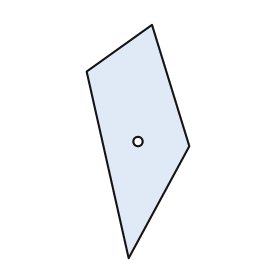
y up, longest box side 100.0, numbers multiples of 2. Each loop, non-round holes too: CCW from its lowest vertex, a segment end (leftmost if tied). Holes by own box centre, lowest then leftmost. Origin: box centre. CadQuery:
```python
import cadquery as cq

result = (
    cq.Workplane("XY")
    .moveTo(-4.0, -50.0)
    .lineTo(22.0, -2.0)
    .lineTo(6.0, 50.0)
    .lineTo(-22.0, 30.0)
    .close()
    .moveTo(0.0, 0.0)
    .circle(2.0)
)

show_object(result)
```